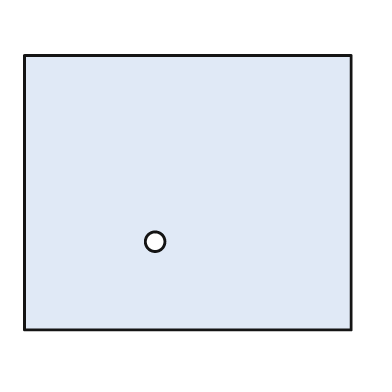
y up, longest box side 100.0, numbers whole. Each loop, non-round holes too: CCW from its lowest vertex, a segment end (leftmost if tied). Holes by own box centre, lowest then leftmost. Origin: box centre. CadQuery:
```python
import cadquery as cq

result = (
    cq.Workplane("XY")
    .moveTo(-50.0, -42.0)
    .lineTo(50.0, -42.0)
    .lineTo(50.0, 42.0)
    .lineTo(-50.0, 42.0)
    .close()
    .moveTo(-10.0, -15.0)
    .circle(3.0)
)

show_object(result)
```